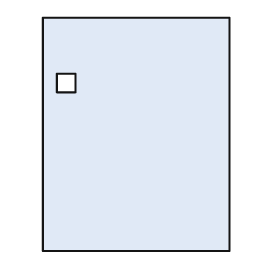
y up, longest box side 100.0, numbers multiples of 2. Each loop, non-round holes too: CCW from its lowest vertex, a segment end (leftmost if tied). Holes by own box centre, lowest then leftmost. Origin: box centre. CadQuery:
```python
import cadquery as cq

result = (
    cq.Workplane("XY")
    .moveTo(-40.0, -50.0)
    .lineTo(40.0, -50.0)
    .lineTo(40.0, 50.0)
    .lineTo(-40.0, 50.0)
    .close()
    .moveTo(-34.0, 18.0)
    .lineTo(-26.0, 18.0)
    .lineTo(-26.0, 26.0)
    .lineTo(-34.0, 26.0)
    .close()
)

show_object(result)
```